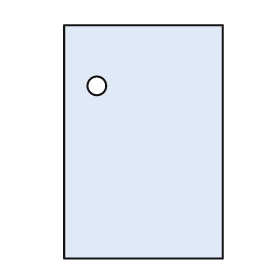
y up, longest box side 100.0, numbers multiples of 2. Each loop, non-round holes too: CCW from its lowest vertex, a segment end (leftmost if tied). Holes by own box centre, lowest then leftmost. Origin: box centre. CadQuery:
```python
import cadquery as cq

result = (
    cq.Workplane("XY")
    .moveTo(-34.0, -50.0)
    .lineTo(34.0, -50.0)
    .lineTo(34.0, 50.0)
    .lineTo(-34.0, 50.0)
    .close()
    .moveTo(-20.0, 24.0)
    .circle(4.0)
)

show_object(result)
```